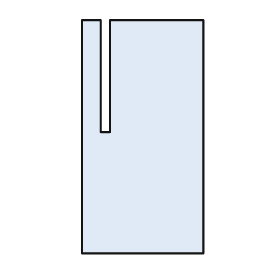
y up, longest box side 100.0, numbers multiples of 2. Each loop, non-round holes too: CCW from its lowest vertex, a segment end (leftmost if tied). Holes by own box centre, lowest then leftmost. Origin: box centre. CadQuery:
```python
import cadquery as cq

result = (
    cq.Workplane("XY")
    .moveTo(-26.0, -50.0)
    .lineTo(26.0, -50.0)
    .lineTo(26.0, 50.0)
    .lineTo(-14.0, 50.0)
    .lineTo(-14.0, 2.0)
    .lineTo(-18.0, 2.0)
    .lineTo(-18.0, 50.0)
    .lineTo(-26.0, 50.0)
    .close()
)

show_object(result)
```